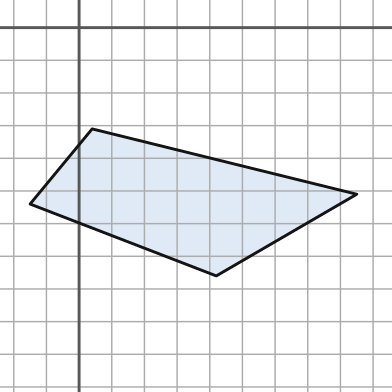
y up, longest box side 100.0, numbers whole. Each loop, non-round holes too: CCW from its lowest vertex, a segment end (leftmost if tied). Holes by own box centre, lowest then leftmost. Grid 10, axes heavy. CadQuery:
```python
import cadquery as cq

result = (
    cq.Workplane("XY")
    .moveTo(42.0, -76.0)
    .lineTo(85.0, -51.0)
    .lineTo(4.0, -31.0)
    .lineTo(-15.0, -54.0)
    .close()
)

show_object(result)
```